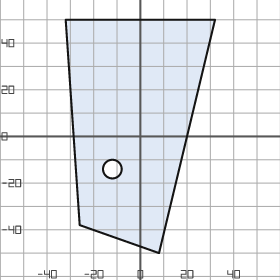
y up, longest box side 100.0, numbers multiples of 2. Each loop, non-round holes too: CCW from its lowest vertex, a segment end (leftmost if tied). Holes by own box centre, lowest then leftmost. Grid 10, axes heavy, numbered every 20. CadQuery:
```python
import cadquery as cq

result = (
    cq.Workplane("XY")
    .moveTo(8.0, -50.0)
    .lineTo(32.0, 50.0)
    .lineTo(-32.0, 50.0)
    .lineTo(-26.0, -38.0)
    .close()
    .moveTo(-12.0, -14.0)
    .circle(4.0)
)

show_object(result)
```